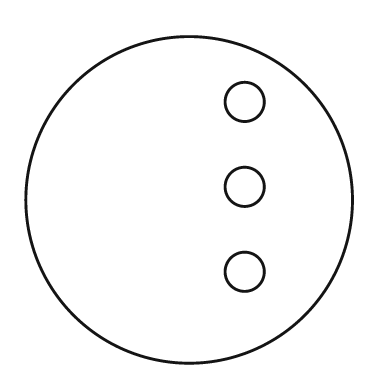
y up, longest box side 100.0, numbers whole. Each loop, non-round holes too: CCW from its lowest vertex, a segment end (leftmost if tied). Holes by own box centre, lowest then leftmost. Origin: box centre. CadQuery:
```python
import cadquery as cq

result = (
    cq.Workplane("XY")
    .moveTo(0.0, 0.0)
    .circle(50.0)
    .moveTo(17.0, -22.0)
    .circle(6.0)
    .moveTo(17.0, 4.0)
    .circle(6.0)
    .moveTo(17.0, 30.0)
    .circle(6.0)
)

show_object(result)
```